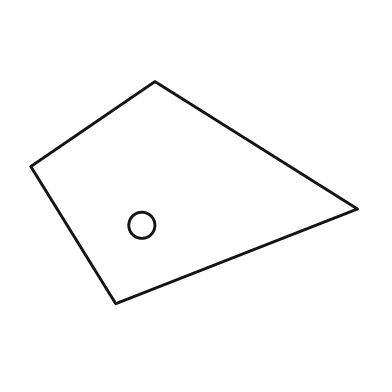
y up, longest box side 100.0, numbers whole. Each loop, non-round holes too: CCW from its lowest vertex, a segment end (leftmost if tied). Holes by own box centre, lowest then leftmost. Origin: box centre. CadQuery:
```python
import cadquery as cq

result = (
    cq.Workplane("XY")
    .moveTo(-24.0, -34.0)
    .lineTo(50.0, -5.0)
    .lineTo(-12.0, 34.0)
    .lineTo(-50.0, 8.0)
    .close()
    .moveTo(-16.0, -10.0)
    .circle(4.0)
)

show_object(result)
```